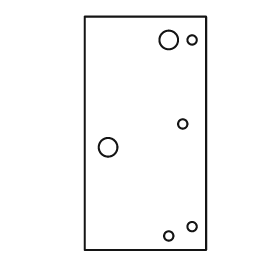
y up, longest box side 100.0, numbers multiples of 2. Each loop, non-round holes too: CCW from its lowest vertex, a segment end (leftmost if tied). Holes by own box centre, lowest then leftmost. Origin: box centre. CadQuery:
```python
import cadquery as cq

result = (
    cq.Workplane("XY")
    .moveTo(-26.0, -50.0)
    .lineTo(26.0, -50.0)
    .lineTo(26.0, 50.0)
    .lineTo(-26.0, 50.0)
    .close()
    .moveTo(10.0, -44.0)
    .circle(2.0)
    .moveTo(20.0, -40.0)
    .circle(2.0)
    .moveTo(-16.0, -6.0)
    .circle(4.0)
    .moveTo(16.0, 4.0)
    .circle(2.0)
    .moveTo(10.0, 40.0)
    .circle(4.0)
    .moveTo(20.0, 40.0)
    .circle(2.0)
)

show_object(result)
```